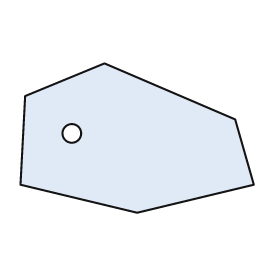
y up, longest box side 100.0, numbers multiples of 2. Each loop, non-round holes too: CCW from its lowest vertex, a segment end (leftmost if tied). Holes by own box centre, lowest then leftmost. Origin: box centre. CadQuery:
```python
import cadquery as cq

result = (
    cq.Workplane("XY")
    .moveTo(0.0, -32.0)
    .lineTo(50.0, -20.0)
    .lineTo(42.0, 8.0)
    .lineTo(-14.0, 32.0)
    .lineTo(-48.0, 18.0)
    .lineTo(-50.0, -20.0)
    .close()
    .moveTo(-28.0, 2.0)
    .circle(4.0)
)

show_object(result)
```